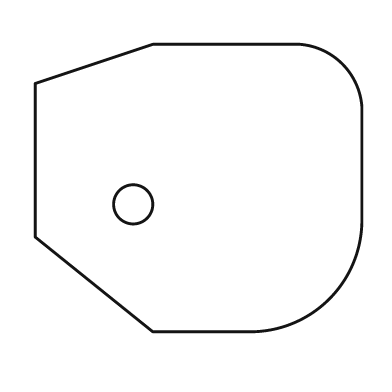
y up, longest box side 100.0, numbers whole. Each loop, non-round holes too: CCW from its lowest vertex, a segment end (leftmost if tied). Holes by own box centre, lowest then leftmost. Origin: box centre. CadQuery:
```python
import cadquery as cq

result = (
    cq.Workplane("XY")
    .moveTo(-14.0, -44.0)
    .lineTo(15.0, -44.0)
    .threePointArc((40.0, -34.0), (50.0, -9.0))
    .lineTo(50.0, 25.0)
    .threePointArc((44.0, 38.0), (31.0, 44.0))
    .lineTo(-14.0, 44.0)
    .lineTo(-50.0, 32.0)
    .lineTo(-50.0, -15.0)
    .close()
    .moveTo(-20.0, -5.0)
    .circle(6.0)
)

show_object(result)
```